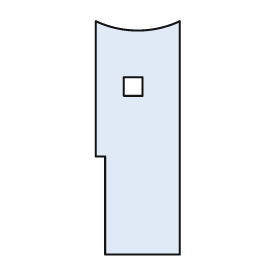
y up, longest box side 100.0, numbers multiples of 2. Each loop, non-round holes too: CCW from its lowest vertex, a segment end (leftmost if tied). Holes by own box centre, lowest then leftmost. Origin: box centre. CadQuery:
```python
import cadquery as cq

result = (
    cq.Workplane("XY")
    .moveTo(-14.0, -50.0)
    .lineTo(18.0, -50.0)
    .lineTo(18.0, 50.0)
    .threePointArc((0.0, 46.0), (-18.0, 50.0))
    .lineTo(-18.0, -8.0)
    .lineTo(-14.0, -8.0)
    .close()
    .moveTo(-6.0, 18.0)
    .lineTo(2.0, 18.0)
    .lineTo(2.0, 26.0)
    .lineTo(-6.0, 26.0)
    .close()
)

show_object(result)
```